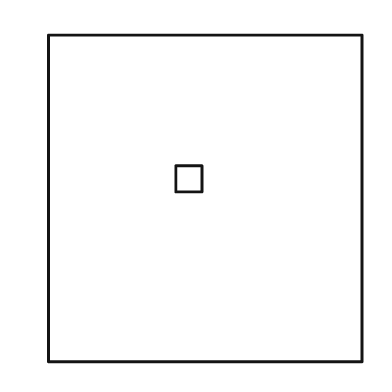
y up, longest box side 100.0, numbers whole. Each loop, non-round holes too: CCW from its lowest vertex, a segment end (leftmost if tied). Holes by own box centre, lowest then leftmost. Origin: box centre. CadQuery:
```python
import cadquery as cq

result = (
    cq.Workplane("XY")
    .moveTo(-48.0, -50.0)
    .lineTo(48.0, -50.0)
    .lineTo(48.0, 50.0)
    .lineTo(-48.0, 50.0)
    .close()
    .moveTo(-9.0, 2.0)
    .lineTo(-1.0, 2.0)
    .lineTo(-1.0, 10.0)
    .lineTo(-9.0, 10.0)
    .close()
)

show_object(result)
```